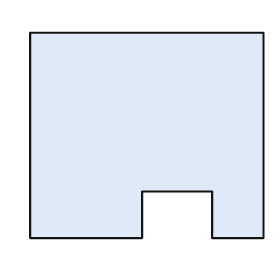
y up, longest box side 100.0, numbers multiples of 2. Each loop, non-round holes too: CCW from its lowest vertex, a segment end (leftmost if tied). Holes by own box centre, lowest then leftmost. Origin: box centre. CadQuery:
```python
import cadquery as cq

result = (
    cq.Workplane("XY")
    .moveTo(-50.0, -44.0)
    .lineTo(-2.0, -44.0)
    .lineTo(-2.0, -24.0)
    .lineTo(28.0, -24.0)
    .lineTo(28.0, -44.0)
    .lineTo(50.0, -44.0)
    .lineTo(50.0, 44.0)
    .lineTo(-50.0, 44.0)
    .close()
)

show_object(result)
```